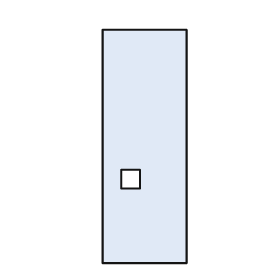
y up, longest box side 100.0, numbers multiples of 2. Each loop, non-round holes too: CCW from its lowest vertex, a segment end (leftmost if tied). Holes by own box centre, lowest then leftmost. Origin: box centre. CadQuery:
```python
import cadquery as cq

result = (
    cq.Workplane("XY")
    .moveTo(-18.0, -50.0)
    .lineTo(18.0, -50.0)
    .lineTo(18.0, 50.0)
    .lineTo(-18.0, 50.0)
    .close()
    .moveTo(-10.0, -18.0)
    .lineTo(-2.0, -18.0)
    .lineTo(-2.0, -10.0)
    .lineTo(-10.0, -10.0)
    .close()
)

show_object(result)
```